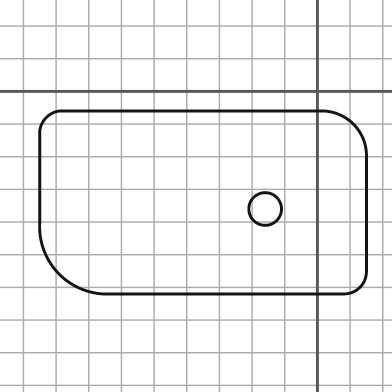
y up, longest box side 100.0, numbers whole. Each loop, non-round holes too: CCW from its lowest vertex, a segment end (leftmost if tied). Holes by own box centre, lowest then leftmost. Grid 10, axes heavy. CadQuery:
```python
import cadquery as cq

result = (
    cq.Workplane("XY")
    .moveTo(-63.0, -62.0)
    .lineTo(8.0, -62.0)
    .threePointArc((13.0, -60.0), (15.0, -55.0))
    .lineTo(15.0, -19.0)
    .threePointArc((11.0, -10.0), (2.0, -6.0))
    .lineTo(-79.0, -6.0)
    .threePointArc((-83.0, -8.0), (-85.0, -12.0))
    .lineTo(-85.0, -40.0)
    .threePointArc((-79.0, -56.0), (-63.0, -62.0))
    .close()
    .moveTo(-16.0, -36.0)
    .circle(5.0)
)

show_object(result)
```